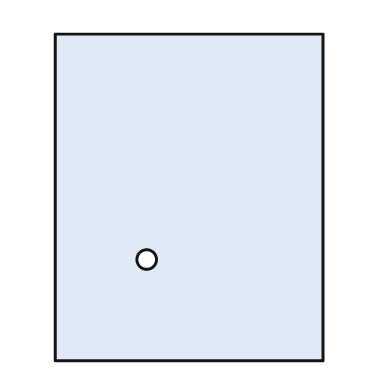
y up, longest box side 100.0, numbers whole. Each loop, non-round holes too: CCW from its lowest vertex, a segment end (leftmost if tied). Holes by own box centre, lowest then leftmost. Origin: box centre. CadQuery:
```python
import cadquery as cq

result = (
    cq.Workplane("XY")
    .moveTo(-41.0, -50.0)
    .lineTo(41.0, -50.0)
    .lineTo(41.0, 50.0)
    .lineTo(-41.0, 50.0)
    .close()
    .moveTo(-13.0, -19.0)
    .circle(3.0)
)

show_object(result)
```